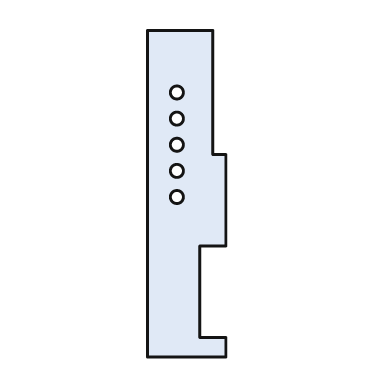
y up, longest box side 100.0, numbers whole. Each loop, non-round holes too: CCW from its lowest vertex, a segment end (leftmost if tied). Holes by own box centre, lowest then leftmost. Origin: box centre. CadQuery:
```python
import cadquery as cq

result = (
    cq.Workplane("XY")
    .moveTo(-12.0, -50.0)
    .lineTo(12.0, -50.0)
    .lineTo(12.0, -44.0)
    .lineTo(4.0, -44.0)
    .lineTo(4.0, -16.0)
    .lineTo(12.0, -16.0)
    .lineTo(12.0, 12.0)
    .lineTo(8.0, 12.0)
    .lineTo(8.0, 50.0)
    .lineTo(-12.0, 50.0)
    .close()
    .moveTo(-3.0, -1.0)
    .circle(2.0)
    .moveTo(-3.0, 7.0)
    .circle(2.0)
    .moveTo(-3.0, 15.0)
    .circle(2.0)
    .moveTo(-3.0, 23.0)
    .circle(2.0)
    .moveTo(-3.0, 31.0)
    .circle(2.0)
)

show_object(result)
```